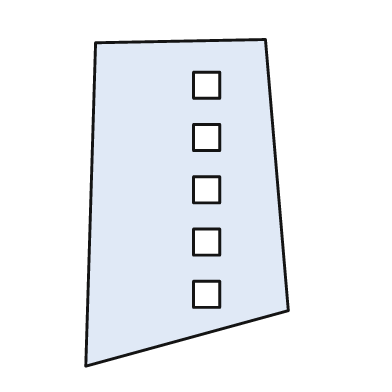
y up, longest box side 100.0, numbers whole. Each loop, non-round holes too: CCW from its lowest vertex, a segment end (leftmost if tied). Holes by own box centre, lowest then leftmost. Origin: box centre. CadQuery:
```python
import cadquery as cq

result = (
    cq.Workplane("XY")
    .moveTo(-31.0, -50.0)
    .lineTo(31.0, -33.0)
    .lineTo(24.0, 50.0)
    .lineTo(-28.0, 49.0)
    .close()
    .moveTo(2.0, -32.0)
    .lineTo(10.0, -32.0)
    .lineTo(10.0, -24.0)
    .lineTo(2.0, -24.0)
    .close()
    .moveTo(2.0, -16.0)
    .lineTo(10.0, -16.0)
    .lineTo(10.0, -8.0)
    .lineTo(2.0, -8.0)
    .close()
    .moveTo(2.0, 0.0)
    .lineTo(10.0, 0.0)
    .lineTo(10.0, 8.0)
    .lineTo(2.0, 8.0)
    .close()
    .moveTo(2.0, 16.0)
    .lineTo(10.0, 16.0)
    .lineTo(10.0, 24.0)
    .lineTo(2.0, 24.0)
    .close()
    .moveTo(2.0, 32.0)
    .lineTo(10.0, 32.0)
    .lineTo(10.0, 40.0)
    .lineTo(2.0, 40.0)
    .close()
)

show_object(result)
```